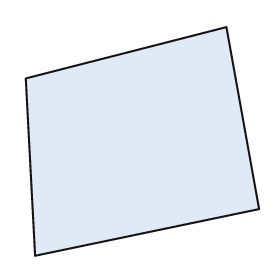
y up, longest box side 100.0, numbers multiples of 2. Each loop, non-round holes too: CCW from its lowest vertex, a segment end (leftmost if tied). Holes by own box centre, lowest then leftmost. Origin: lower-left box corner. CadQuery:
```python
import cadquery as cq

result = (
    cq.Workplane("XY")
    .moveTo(4.0, 0.0)
    .lineTo(100.0, 20.0)
    .lineTo(86.0, 98.0)
    .lineTo(0.0, 76.0)
    .close()
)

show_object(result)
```